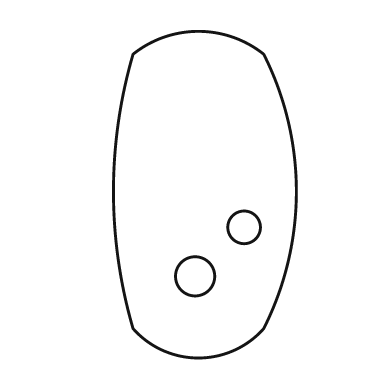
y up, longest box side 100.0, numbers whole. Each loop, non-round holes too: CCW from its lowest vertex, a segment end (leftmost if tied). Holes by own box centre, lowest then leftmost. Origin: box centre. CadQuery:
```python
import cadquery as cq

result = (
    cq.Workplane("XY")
    .moveTo(-22.0, -41.0)
    .threePointArc((-2.0, -50.0), (18.0, -41.0))
    .threePointArc((28.0, 1.0), (18.0, 43.0))
    .threePointArc((-2.0, 50.0), (-22.0, 43.0))
    .threePointArc((-28.0, 1.0), (-22.0, -41.0))
    .close()
    .moveTo(-3.0, -25.0)
    .circle(6.0)
    .moveTo(12.0, -10.0)
    .circle(5.0)
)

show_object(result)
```